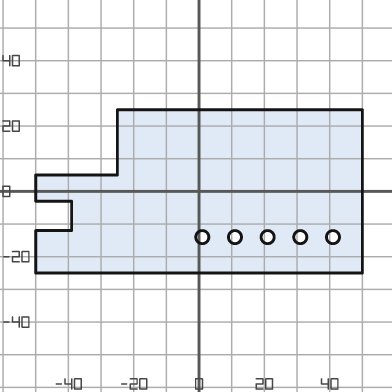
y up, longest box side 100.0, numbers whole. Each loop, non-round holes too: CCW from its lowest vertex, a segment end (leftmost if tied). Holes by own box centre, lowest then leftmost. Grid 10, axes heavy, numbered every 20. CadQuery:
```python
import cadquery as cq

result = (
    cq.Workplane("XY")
    .moveTo(-50.0, -25.0)
    .lineTo(50.0, -25.0)
    .lineTo(50.0, 25.0)
    .lineTo(-25.0, 25.0)
    .lineTo(-25.0, 5.0)
    .lineTo(-50.0, 5.0)
    .lineTo(-50.0, -3.0)
    .lineTo(-39.0, -3.0)
    .lineTo(-39.0, -12.0)
    .lineTo(-50.0, -12.0)
    .close()
    .moveTo(1.0, -14.0)
    .circle(2.0)
    .moveTo(11.0, -14.0)
    .circle(2.0)
    .moveTo(21.0, -14.0)
    .circle(2.0)
    .moveTo(31.0, -14.0)
    .circle(2.0)
    .moveTo(41.0, -14.0)
    .circle(2.0)
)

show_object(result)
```